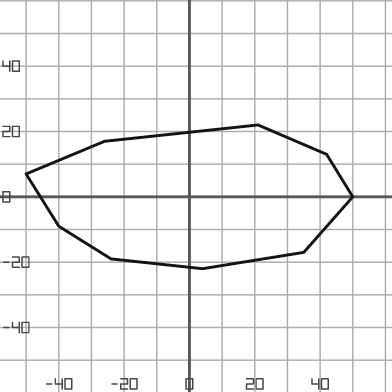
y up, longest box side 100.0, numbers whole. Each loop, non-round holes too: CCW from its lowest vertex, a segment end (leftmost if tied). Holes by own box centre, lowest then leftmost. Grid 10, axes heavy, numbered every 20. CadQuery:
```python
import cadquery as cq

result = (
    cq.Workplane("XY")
    .moveTo(4.0, -22.0)
    .lineTo(35.0, -17.0)
    .lineTo(50.0, 0.0)
    .lineTo(42.0, 13.0)
    .lineTo(21.0, 22.0)
    .lineTo(-26.0, 17.0)
    .lineTo(-50.0, 7.0)
    .lineTo(-40.0, -9.0)
    .lineTo(-24.0, -19.0)
    .close()
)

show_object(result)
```